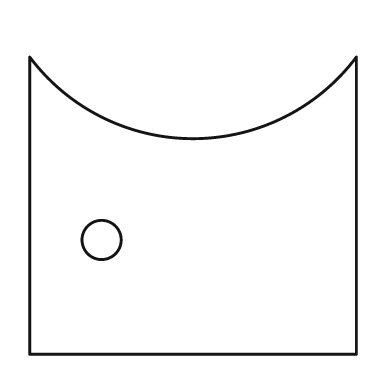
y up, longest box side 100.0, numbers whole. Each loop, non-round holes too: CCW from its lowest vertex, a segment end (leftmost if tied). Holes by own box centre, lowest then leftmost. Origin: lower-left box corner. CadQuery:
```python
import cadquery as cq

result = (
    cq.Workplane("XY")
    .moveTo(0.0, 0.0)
    .lineTo(100.0, 0.0)
    .lineTo(100.0, 91.0)
    .threePointArc((50.0, 66.0), (0.0, 91.0))
    .close()
    .moveTo(22.0, 35.0)
    .circle(6.0)
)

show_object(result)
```